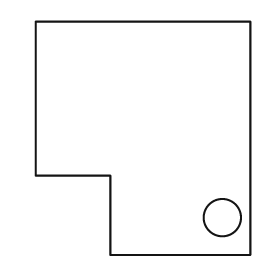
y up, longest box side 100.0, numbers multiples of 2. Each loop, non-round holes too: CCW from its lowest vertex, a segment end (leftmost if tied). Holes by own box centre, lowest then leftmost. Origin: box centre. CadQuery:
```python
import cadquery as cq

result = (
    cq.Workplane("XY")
    .moveTo(-14.0, -50.0)
    .lineTo(46.0, -50.0)
    .lineTo(46.0, 50.0)
    .lineTo(-46.0, 50.0)
    .lineTo(-46.0, -16.0)
    .lineTo(-14.0, -16.0)
    .close()
    .moveTo(34.0, -34.0)
    .circle(8.0)
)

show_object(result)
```